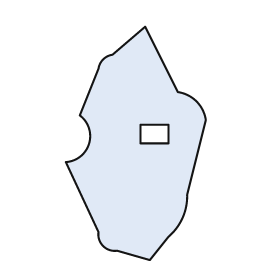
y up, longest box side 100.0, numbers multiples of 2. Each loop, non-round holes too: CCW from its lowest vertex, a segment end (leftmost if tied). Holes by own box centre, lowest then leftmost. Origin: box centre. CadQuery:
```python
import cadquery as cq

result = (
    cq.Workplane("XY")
    .moveTo(6.0, -50.0)
    .lineTo(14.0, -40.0)
    .threePointArc((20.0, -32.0), (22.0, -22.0))
    .lineTo(30.0, 10.0)
    .threePointArc((26.0, 18.0), (18.0, 22.0))
    .lineTo(4.0, 50.0)
    .lineTo(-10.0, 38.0)
    .threePointArc((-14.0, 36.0), (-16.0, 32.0))
    .lineTo(-24.0, 12.0)
    .threePointArc((-20.0, 0.0), (-30.0, -8.0))
    .lineTo(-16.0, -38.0)
    .threePointArc((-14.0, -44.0), (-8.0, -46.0))
    .close()
    .moveTo(2.0, 0.0)
    .lineTo(14.0, 0.0)
    .lineTo(14.0, 8.0)
    .lineTo(2.0, 8.0)
    .close()
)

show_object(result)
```